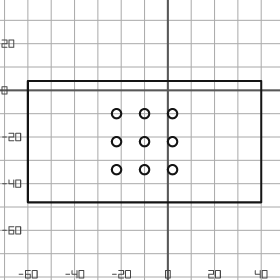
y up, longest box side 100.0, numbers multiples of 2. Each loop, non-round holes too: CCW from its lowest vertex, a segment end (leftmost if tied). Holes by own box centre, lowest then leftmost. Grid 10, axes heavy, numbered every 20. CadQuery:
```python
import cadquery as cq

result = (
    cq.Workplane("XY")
    .moveTo(-60.0, -48.0)
    .lineTo(40.0, -48.0)
    .lineTo(40.0, 4.0)
    .lineTo(-60.0, 4.0)
    .close()
    .moveTo(-22.0, -34.0)
    .circle(2.0)
    .moveTo(-10.0, -34.0)
    .circle(2.0)
    .moveTo(2.0, -34.0)
    .circle(2.0)
    .moveTo(-22.0, -22.0)
    .circle(2.0)
    .moveTo(-10.0, -22.0)
    .circle(2.0)
    .moveTo(2.0, -22.0)
    .circle(2.0)
    .moveTo(-22.0, -10.0)
    .circle(2.0)
    .moveTo(-10.0, -10.0)
    .circle(2.0)
    .moveTo(2.0, -10.0)
    .circle(2.0)
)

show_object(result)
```